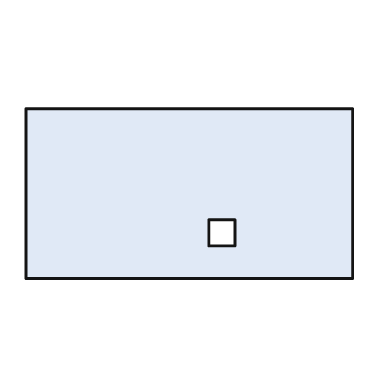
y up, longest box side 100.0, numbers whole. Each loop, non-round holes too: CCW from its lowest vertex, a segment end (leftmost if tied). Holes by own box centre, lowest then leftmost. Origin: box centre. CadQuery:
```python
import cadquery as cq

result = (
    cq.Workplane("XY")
    .moveTo(-50.0, -26.0)
    .lineTo(50.0, -26.0)
    .lineTo(50.0, 26.0)
    .lineTo(-50.0, 26.0)
    .close()
    .moveTo(6.0, -16.0)
    .lineTo(14.0, -16.0)
    .lineTo(14.0, -8.0)
    .lineTo(6.0, -8.0)
    .close()
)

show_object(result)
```